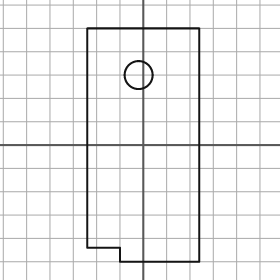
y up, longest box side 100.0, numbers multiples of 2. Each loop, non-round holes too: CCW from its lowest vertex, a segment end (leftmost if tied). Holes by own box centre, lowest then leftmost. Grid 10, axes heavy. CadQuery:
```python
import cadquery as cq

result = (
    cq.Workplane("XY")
    .moveTo(-10.0, -50.0)
    .lineTo(24.0, -50.0)
    .lineTo(24.0, 50.0)
    .lineTo(-24.0, 50.0)
    .lineTo(-24.0, -44.0)
    .lineTo(-10.0, -44.0)
    .close()
    .moveTo(-2.0, 30.0)
    .circle(6.0)
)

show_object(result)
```